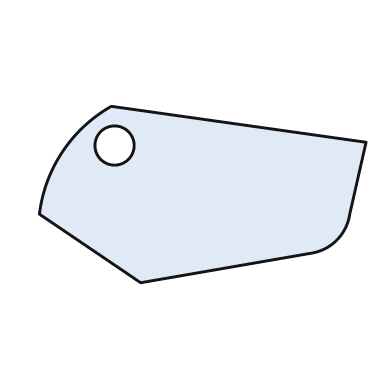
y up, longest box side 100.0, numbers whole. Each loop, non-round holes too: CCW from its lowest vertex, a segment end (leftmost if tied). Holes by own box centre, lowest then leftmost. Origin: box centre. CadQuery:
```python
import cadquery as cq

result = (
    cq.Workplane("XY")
    .moveTo(-19.0, -27.0)
    .lineTo(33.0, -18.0)
    .threePointArc((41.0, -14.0), (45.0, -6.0))
    .lineTo(50.0, 16.0)
    .lineTo(-28.0, 27.0)
    .threePointArc((-43.0, 13.0), (-50.0, -6.0))
    .close()
    .moveTo(-27.0, 15.0)
    .circle(6.0)
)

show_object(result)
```